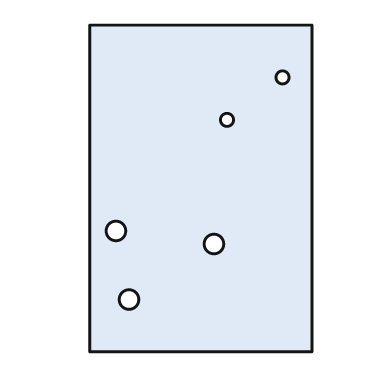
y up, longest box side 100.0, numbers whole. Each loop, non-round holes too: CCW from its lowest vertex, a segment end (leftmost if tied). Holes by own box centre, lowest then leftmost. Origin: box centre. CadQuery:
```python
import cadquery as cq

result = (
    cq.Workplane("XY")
    .moveTo(-34.0, -50.0)
    .lineTo(34.0, -50.0)
    .lineTo(34.0, 50.0)
    .lineTo(-34.0, 50.0)
    .close()
    .moveTo(-22.0, -34.0)
    .circle(3.0)
    .moveTo(4.0, -17.0)
    .circle(3.0)
    .moveTo(-26.0, -13.0)
    .circle(3.0)
    .moveTo(8.0, 21.0)
    .circle(2.0)
    .moveTo(25.0, 34.0)
    .circle(2.0)
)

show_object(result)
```